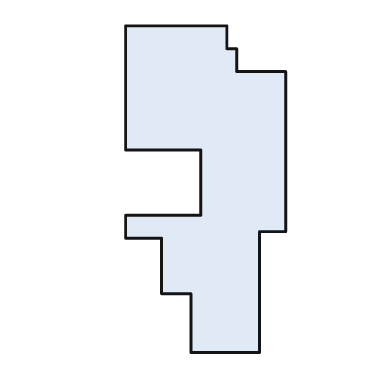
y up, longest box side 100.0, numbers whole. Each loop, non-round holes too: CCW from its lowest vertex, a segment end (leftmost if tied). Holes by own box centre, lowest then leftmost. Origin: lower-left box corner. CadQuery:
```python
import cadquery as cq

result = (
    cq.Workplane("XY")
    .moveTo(20.0, 0.0)
    .lineTo(41.0, 0.0)
    .lineTo(41.0, 37.0)
    .lineTo(49.0, 37.0)
    .lineTo(49.0, 86.0)
    .lineTo(34.0, 86.0)
    .lineTo(34.0, 93.0)
    .lineTo(31.0, 93.0)
    .lineTo(31.0, 100.0)
    .lineTo(0.0, 100.0)
    .lineTo(0.0, 62.0)
    .lineTo(23.0, 62.0)
    .lineTo(23.0, 42.0)
    .lineTo(0.0, 42.0)
    .lineTo(0.0, 35.0)
    .lineTo(11.0, 35.0)
    .lineTo(11.0, 18.0)
    .lineTo(20.0, 18.0)
    .close()
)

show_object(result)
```